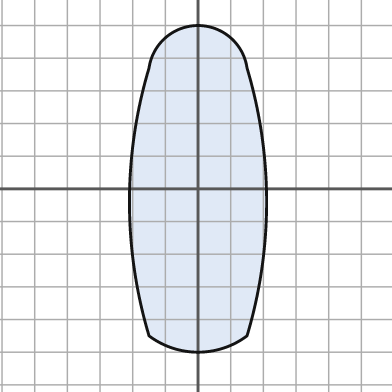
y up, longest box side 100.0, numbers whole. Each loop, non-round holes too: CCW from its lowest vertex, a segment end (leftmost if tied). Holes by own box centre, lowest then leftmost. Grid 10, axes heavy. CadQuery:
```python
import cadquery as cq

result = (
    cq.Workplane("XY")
    .moveTo(-15.0, -45.0)
    .threePointArc((0.0, -50.0), (15.0, -45.0))
    .threePointArc((21.0, -4.0), (15.0, 37.0))
    .threePointArc((0.0, 50.0), (-15.0, 37.0))
    .threePointArc((-21.0, -4.0), (-15.0, -45.0))
    .close()
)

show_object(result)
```